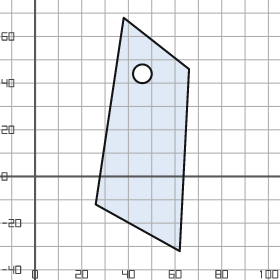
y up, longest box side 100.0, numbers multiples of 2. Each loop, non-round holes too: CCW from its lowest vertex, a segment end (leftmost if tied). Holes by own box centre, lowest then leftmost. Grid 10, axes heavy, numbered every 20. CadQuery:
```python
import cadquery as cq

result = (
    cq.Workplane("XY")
    .moveTo(62.0, -32.0)
    .lineTo(66.0, 46.0)
    .lineTo(38.0, 68.0)
    .lineTo(26.0, -12.0)
    .close()
    .moveTo(46.0, 44.0)
    .circle(4.0)
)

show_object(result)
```